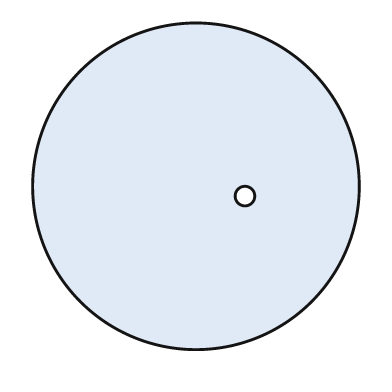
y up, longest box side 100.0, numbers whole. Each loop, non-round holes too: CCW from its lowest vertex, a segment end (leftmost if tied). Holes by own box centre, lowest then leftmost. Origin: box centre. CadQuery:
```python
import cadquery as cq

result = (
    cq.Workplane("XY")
    .moveTo(0.0, 0.0)
    .circle(50.0)
    .moveTo(15.0, -3.0)
    .circle(3.0)
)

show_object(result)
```